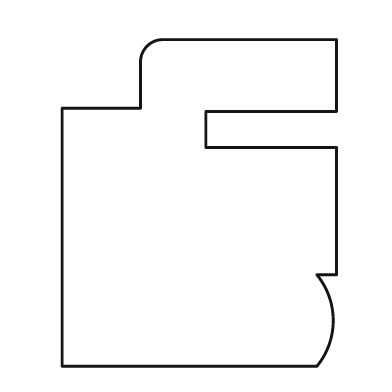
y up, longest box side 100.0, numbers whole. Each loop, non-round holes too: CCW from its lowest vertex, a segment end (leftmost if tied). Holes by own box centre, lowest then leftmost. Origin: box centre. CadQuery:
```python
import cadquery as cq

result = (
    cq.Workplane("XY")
    .moveTo(-42.0, -50.0)
    .lineTo(36.0, -50.0)
    .threePointArc((41.0, -36.0), (36.0, -22.0))
    .lineTo(42.0, -22.0)
    .lineTo(42.0, 17.0)
    .lineTo(2.0, 17.0)
    .lineTo(2.0, 28.0)
    .lineTo(42.0, 28.0)
    .lineTo(42.0, 50.0)
    .lineTo(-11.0, 50.0)
    .threePointArc((-16.0, 48.0), (-18.0, 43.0))
    .lineTo(-18.0, 29.0)
    .lineTo(-42.0, 29.0)
    .close()
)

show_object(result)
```